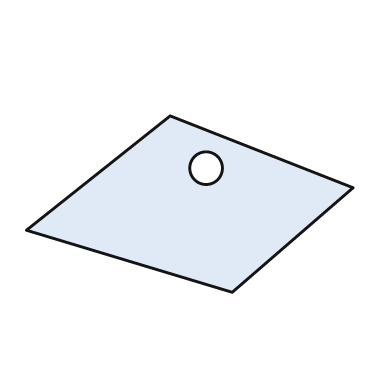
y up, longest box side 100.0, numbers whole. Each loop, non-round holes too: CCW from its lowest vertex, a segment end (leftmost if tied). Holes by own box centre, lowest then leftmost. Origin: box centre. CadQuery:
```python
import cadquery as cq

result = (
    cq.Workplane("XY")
    .moveTo(13.0, -27.0)
    .lineTo(50.0, 5.0)
    .lineTo(-6.0, 27.0)
    .lineTo(-50.0, -8.0)
    .close()
    .moveTo(5.0, 11.0)
    .circle(5.0)
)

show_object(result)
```